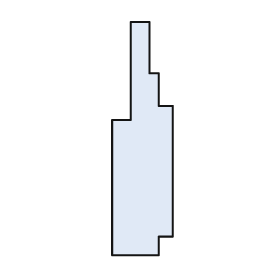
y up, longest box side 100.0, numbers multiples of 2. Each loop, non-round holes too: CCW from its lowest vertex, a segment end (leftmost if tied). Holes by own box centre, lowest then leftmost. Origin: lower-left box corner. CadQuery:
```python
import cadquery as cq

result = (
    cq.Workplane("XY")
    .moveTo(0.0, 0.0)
    .lineTo(20.0, 0.0)
    .lineTo(20.0, 8.0)
    .lineTo(26.0, 8.0)
    .lineTo(26.0, 64.0)
    .lineTo(20.0, 64.0)
    .lineTo(20.0, 78.0)
    .lineTo(16.0, 78.0)
    .lineTo(16.0, 100.0)
    .lineTo(8.0, 100.0)
    .lineTo(8.0, 58.0)
    .lineTo(0.0, 58.0)
    .close()
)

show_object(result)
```